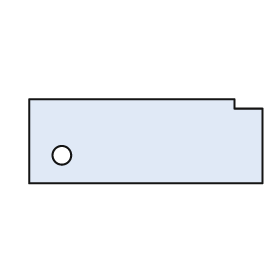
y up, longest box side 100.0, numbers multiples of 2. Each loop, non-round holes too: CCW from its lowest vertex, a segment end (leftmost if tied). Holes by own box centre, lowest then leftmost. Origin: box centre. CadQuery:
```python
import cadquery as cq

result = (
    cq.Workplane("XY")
    .moveTo(-50.0, -18.0)
    .lineTo(50.0, -18.0)
    .lineTo(50.0, 14.0)
    .lineTo(38.0, 14.0)
    .lineTo(38.0, 18.0)
    .lineTo(-50.0, 18.0)
    .close()
    .moveTo(-36.0, -6.0)
    .circle(4.0)
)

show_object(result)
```